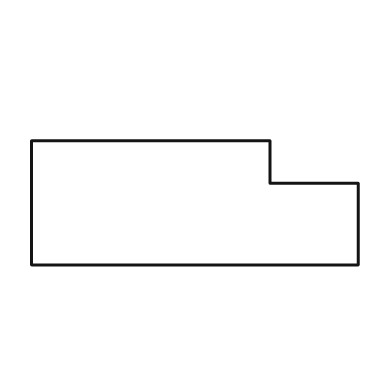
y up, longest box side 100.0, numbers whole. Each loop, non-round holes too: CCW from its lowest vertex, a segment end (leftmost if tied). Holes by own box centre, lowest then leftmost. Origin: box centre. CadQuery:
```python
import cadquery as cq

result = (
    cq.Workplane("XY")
    .moveTo(-50.0, -19.0)
    .lineTo(50.0, -19.0)
    .lineTo(50.0, 6.0)
    .lineTo(23.0, 6.0)
    .lineTo(23.0, 19.0)
    .lineTo(-50.0, 19.0)
    .close()
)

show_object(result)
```